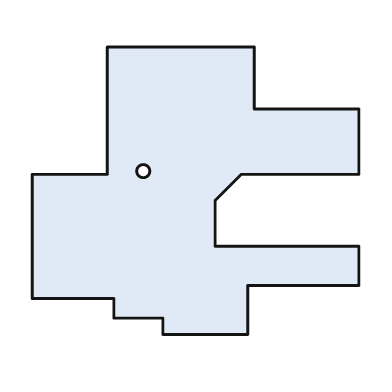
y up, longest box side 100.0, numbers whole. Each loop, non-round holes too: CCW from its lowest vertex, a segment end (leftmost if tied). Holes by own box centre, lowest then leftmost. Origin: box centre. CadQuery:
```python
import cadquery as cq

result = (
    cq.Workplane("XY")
    .moveTo(-10.0, -44.0)
    .lineTo(16.0, -44.0)
    .lineTo(16.0, -29.0)
    .lineTo(50.0, -29.0)
    .lineTo(50.0, -17.0)
    .lineTo(6.0, -17.0)
    .lineTo(6.0, -3.0)
    .lineTo(14.0, 5.0)
    .lineTo(50.0, 5.0)
    .lineTo(50.0, 25.0)
    .lineTo(18.0, 25.0)
    .lineTo(18.0, 44.0)
    .lineTo(-27.0, 44.0)
    .lineTo(-27.0, 5.0)
    .lineTo(-50.0, 5.0)
    .lineTo(-50.0, -33.0)
    .lineTo(-25.0, -33.0)
    .lineTo(-25.0, -39.0)
    .lineTo(-10.0, -39.0)
    .close()
    .moveTo(-16.0, 6.0)
    .circle(2.0)
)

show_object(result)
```